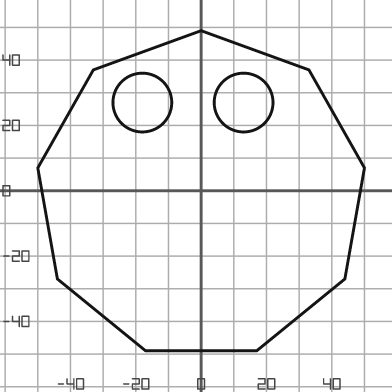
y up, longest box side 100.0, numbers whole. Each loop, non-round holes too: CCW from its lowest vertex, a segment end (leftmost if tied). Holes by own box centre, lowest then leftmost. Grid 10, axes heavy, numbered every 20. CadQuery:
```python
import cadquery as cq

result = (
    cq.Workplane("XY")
    .moveTo(-17.0, -49.0)
    .lineTo(17.0, -49.0)
    .lineTo(44.0, -27.0)
    .lineTo(50.0, 7.0)
    .lineTo(33.0, 37.0)
    .lineTo(0.0, 49.0)
    .lineTo(-33.0, 37.0)
    .lineTo(-50.0, 7.0)
    .lineTo(-44.0, -27.0)
    .close()
    .moveTo(-18.0, 27.0)
    .circle(9.0)
    .moveTo(13.0, 27.0)
    .circle(9.0)
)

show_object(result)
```